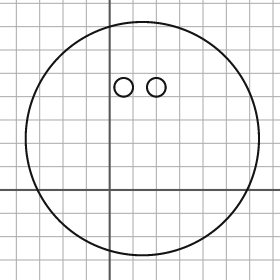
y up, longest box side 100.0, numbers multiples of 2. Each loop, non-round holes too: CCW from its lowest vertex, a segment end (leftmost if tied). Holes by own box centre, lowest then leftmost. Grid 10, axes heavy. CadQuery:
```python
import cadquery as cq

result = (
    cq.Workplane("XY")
    .moveTo(14.0, 22.0)
    .circle(50.0)
    .moveTo(6.0, 44.0)
    .circle(4.0)
    .moveTo(20.0, 44.0)
    .circle(4.0)
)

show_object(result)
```